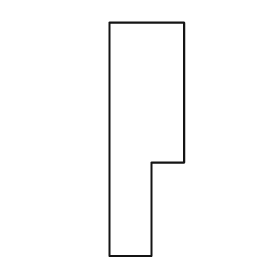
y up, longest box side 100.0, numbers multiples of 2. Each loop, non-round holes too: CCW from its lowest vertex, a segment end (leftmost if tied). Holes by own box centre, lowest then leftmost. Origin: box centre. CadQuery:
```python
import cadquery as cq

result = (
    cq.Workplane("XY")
    .moveTo(-16.0, -50.0)
    .lineTo(2.0, -50.0)
    .lineTo(2.0, -10.0)
    .lineTo(16.0, -10.0)
    .lineTo(16.0, 50.0)
    .lineTo(-16.0, 50.0)
    .close()
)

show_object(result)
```